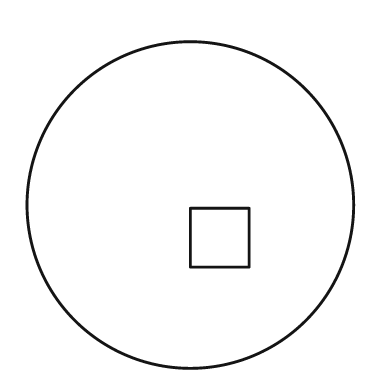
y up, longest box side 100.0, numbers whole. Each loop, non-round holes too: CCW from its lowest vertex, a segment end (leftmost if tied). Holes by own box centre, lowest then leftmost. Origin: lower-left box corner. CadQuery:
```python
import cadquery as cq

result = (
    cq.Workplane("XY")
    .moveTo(50.0, 50.0)
    .circle(50.0)
    .moveTo(50.0, 31.0)
    .lineTo(68.0, 31.0)
    .lineTo(68.0, 49.0)
    .lineTo(50.0, 49.0)
    .close()
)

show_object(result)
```